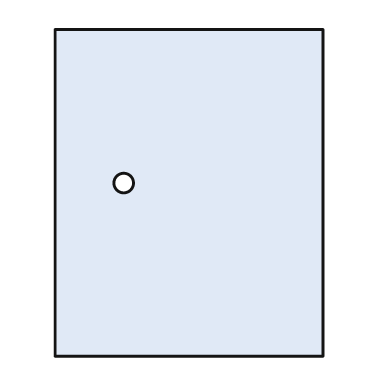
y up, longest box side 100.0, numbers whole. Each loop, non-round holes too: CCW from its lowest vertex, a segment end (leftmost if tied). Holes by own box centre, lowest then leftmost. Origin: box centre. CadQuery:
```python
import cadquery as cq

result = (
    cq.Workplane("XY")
    .moveTo(-41.0, -50.0)
    .lineTo(41.0, -50.0)
    .lineTo(41.0, 50.0)
    .lineTo(-41.0, 50.0)
    .close()
    .moveTo(-20.0, 3.0)
    .circle(3.0)
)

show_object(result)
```